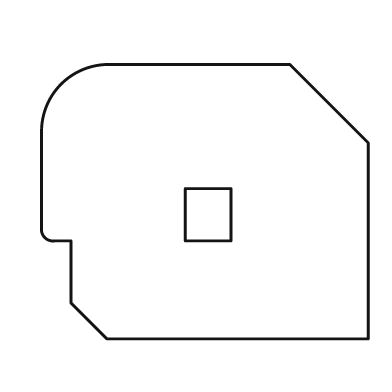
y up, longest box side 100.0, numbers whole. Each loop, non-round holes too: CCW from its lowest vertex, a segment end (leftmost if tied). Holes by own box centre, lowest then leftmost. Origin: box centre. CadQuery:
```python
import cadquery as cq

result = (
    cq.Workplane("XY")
    .moveTo(-30.0, -42.0)
    .lineTo(50.0, -42.0)
    .lineTo(50.0, 18.0)
    .lineTo(26.0, 42.0)
    .lineTo(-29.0, 42.0)
    .threePointArc((-44.0, 36.0), (-50.0, 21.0))
    .lineTo(-50.0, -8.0)
    .threePointArc((-49.0, -11.0), (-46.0, -12.0))
    .lineTo(-41.0, -12.0)
    .lineTo(-41.0, -31.0)
    .close()
    .moveTo(-6.0, -12.0)
    .lineTo(8.0, -12.0)
    .lineTo(8.0, 4.0)
    .lineTo(-6.0, 4.0)
    .close()
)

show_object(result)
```